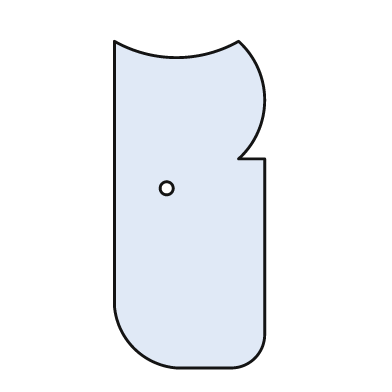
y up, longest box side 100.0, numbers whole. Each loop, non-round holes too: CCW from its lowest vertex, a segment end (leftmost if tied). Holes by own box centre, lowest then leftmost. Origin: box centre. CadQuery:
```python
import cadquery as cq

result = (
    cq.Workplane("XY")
    .moveTo(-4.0, -50.0)
    .lineTo(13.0, -50.0)
    .threePointArc((20.0, -47.0), (23.0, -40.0))
    .lineTo(23.0, 14.0)
    .lineTo(15.0, 14.0)
    .threePointArc((23.0, 32.0), (15.0, 50.0))
    .threePointArc((-4.0, 45.0), (-23.0, 50.0))
    .lineTo(-23.0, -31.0)
    .threePointArc((-17.0, -44.0), (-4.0, -50.0))
    .close()
    .moveTo(-7.0, 5.0)
    .circle(2.0)
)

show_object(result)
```